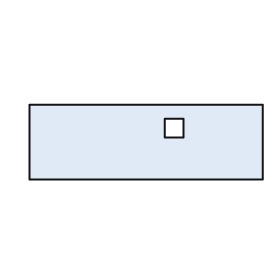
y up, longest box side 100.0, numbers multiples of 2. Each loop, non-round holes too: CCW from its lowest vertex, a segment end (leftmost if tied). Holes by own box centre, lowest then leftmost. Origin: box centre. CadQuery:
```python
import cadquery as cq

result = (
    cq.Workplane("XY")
    .moveTo(-50.0, -16.0)
    .lineTo(50.0, -16.0)
    .lineTo(50.0, 16.0)
    .lineTo(-50.0, 16.0)
    .close()
    .moveTo(8.0, 2.0)
    .lineTo(16.0, 2.0)
    .lineTo(16.0, 10.0)
    .lineTo(8.0, 10.0)
    .close()
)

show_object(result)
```